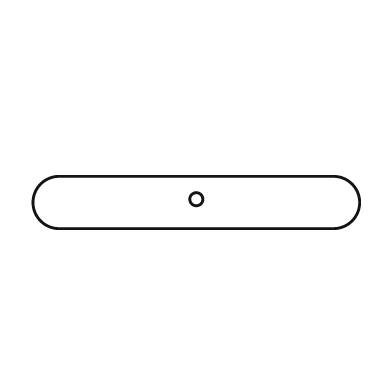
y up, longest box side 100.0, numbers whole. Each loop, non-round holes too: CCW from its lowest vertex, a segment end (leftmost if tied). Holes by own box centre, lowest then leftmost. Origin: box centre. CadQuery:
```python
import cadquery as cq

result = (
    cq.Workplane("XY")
    .moveTo(-42.0, -8.0)
    .lineTo(42.0, -8.0)
    .threePointArc((50.0, 0.0), (42.0, 8.0))
    .lineTo(-42.0, 8.0)
    .threePointArc((-50.0, 0.0), (-42.0, -8.0))
    .close()
    .moveTo(0.0, 1.0)
    .circle(2.0)
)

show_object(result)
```